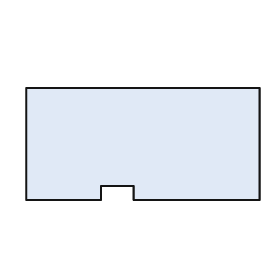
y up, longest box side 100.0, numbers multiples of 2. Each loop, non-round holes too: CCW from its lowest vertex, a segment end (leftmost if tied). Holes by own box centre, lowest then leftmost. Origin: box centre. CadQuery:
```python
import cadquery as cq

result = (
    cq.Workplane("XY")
    .moveTo(-50.0, -24.0)
    .lineTo(-18.0, -24.0)
    .lineTo(-18.0, -18.0)
    .lineTo(-4.0, -18.0)
    .lineTo(-4.0, -24.0)
    .lineTo(50.0, -24.0)
    .lineTo(50.0, 24.0)
    .lineTo(-50.0, 24.0)
    .close()
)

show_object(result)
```